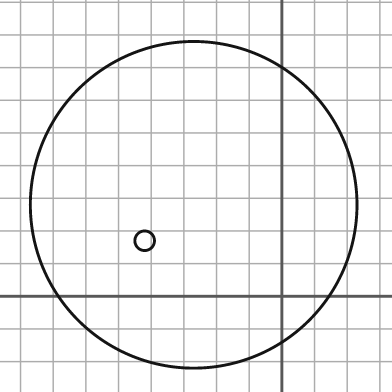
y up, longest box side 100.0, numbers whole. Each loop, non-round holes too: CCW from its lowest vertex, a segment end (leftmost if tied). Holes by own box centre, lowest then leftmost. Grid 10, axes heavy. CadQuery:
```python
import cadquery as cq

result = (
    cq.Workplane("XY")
    .moveTo(-27.0, 28.0)
    .circle(50.0)
    .moveTo(-42.0, 17.0)
    .circle(3.0)
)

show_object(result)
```